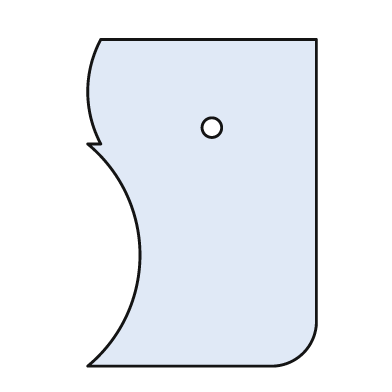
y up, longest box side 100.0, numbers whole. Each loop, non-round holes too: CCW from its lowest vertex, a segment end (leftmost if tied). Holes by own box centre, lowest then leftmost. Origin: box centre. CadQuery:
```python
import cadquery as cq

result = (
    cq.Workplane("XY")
    .moveTo(-35.0, -50.0)
    .lineTo(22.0, -50.0)
    .threePointArc((31.0, -46.0), (35.0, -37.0))
    .lineTo(35.0, 50.0)
    .lineTo(-31.0, 50.0)
    .threePointArc((-35.0, 34.0), (-31.0, 18.0))
    .lineTo(-35.0, 18.0)
    .threePointArc((-19.0, -16.0), (-35.0, -50.0))
    .close()
    .moveTo(3.0, 23.0)
    .circle(3.0)
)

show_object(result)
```